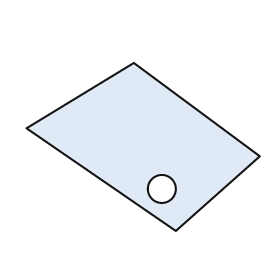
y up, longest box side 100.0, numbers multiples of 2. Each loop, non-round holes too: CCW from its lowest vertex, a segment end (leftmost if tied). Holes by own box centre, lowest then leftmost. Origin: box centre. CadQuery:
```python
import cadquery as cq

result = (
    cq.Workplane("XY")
    .moveTo(14.0, -36.0)
    .lineTo(50.0, -4.0)
    .lineTo(-4.0, 36.0)
    .lineTo(-50.0, 8.0)
    .close()
    .moveTo(8.0, -18.0)
    .circle(6.0)
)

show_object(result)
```